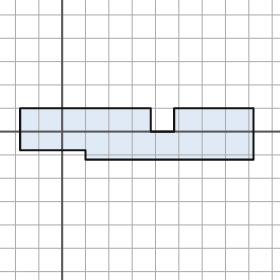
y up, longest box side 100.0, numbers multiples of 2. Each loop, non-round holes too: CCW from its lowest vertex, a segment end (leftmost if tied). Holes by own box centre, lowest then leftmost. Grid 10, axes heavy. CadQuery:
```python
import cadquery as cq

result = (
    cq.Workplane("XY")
    .moveTo(10.0, -12.0)
    .lineTo(82.0, -12.0)
    .lineTo(82.0, 10.0)
    .lineTo(48.0, 10.0)
    .lineTo(48.0, 0.0)
    .lineTo(38.0, 0.0)
    .lineTo(38.0, 10.0)
    .lineTo(-18.0, 10.0)
    .lineTo(-18.0, -8.0)
    .lineTo(10.0, -8.0)
    .close()
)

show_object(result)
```